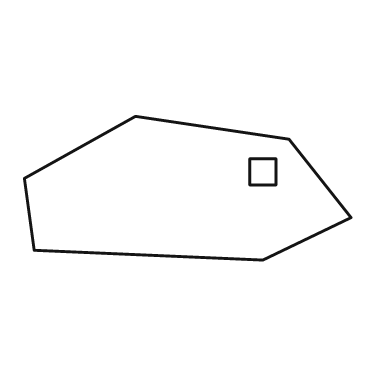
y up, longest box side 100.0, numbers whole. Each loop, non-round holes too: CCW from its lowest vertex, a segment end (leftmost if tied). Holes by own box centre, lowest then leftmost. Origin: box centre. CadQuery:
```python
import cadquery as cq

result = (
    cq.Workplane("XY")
    .moveTo(23.0, -22.0)
    .lineTo(50.0, -9.0)
    .lineTo(31.0, 15.0)
    .lineTo(-16.0, 22.0)
    .lineTo(-50.0, 3.0)
    .lineTo(-47.0, -19.0)
    .close()
    .moveTo(19.0, 1.0)
    .lineTo(27.0, 1.0)
    .lineTo(27.0, 9.0)
    .lineTo(19.0, 9.0)
    .close()
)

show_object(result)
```